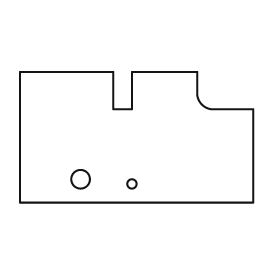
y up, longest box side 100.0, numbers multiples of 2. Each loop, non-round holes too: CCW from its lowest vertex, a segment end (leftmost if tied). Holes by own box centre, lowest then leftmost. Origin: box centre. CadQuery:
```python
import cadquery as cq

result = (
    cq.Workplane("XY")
    .moveTo(-50.0, -28.0)
    .lineTo(50.0, -28.0)
    .lineTo(50.0, 12.0)
    .lineTo(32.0, 12.0)
    .threePointArc((28.0, 14.0), (26.0, 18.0))
    .lineTo(26.0, 28.0)
    .lineTo(-2.0, 28.0)
    .lineTo(-2.0, 12.0)
    .lineTo(-10.0, 12.0)
    .lineTo(-10.0, 28.0)
    .lineTo(-50.0, 28.0)
    .close()
    .moveTo(-2.0, -20.0)
    .circle(2.0)
    .moveTo(-24.0, -18.0)
    .circle(4.0)
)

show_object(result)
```